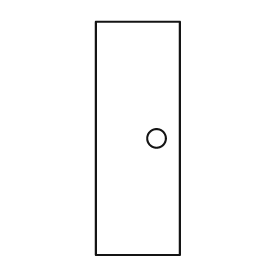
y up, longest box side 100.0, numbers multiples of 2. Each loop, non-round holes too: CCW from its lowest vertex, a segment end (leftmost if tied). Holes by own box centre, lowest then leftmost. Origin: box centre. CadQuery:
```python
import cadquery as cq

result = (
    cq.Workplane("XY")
    .moveTo(-18.0, -50.0)
    .lineTo(18.0, -50.0)
    .lineTo(18.0, 50.0)
    .lineTo(-18.0, 50.0)
    .close()
    .moveTo(8.0, 0.0)
    .circle(4.0)
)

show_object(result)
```